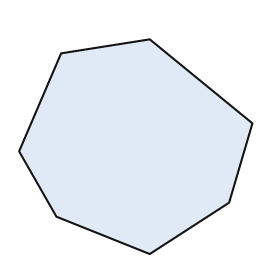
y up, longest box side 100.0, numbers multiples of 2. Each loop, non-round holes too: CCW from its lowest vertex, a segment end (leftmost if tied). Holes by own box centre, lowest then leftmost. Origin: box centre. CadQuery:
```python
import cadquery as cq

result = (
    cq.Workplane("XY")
    .moveTo(6.0, -46.0)
    .lineTo(40.0, -24.0)
    .lineTo(50.0, 10.0)
    .lineTo(6.0, 46.0)
    .lineTo(-32.0, 40.0)
    .lineTo(-50.0, -2.0)
    .lineTo(-34.0, -30.0)
    .close()
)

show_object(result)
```